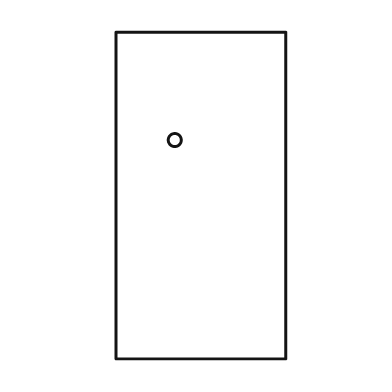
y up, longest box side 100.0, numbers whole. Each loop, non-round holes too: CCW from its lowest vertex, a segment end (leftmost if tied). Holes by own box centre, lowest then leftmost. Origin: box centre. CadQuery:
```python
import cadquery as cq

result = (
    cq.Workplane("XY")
    .moveTo(-26.0, -50.0)
    .lineTo(26.0, -50.0)
    .lineTo(26.0, 50.0)
    .lineTo(-26.0, 50.0)
    .close()
    .moveTo(-8.0, 17.0)
    .circle(2.0)
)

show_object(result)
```